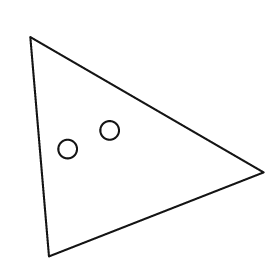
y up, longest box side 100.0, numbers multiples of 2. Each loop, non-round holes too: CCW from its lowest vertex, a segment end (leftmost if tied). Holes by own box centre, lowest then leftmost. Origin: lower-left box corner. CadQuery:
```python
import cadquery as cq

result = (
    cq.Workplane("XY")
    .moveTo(8.0, 0.0)
    .lineTo(100.0, 36.0)
    .lineTo(0.0, 94.0)
    .close()
    .moveTo(16.0, 46.0)
    .circle(4.0)
    .moveTo(34.0, 54.0)
    .circle(4.0)
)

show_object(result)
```